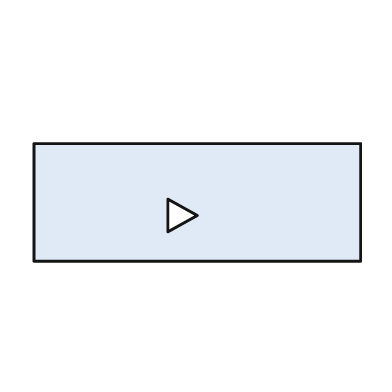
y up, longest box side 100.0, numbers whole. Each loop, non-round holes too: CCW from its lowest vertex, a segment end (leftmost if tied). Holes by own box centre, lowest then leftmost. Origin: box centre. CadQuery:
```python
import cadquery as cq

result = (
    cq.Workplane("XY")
    .moveTo(-50.0, -18.0)
    .lineTo(50.0, -18.0)
    .lineTo(50.0, 18.0)
    .lineTo(-50.0, 18.0)
    .close()
    .moveTo(-9.0, -9.0)
    .lineTo(0.0, -4.0)
    .lineTo(-9.0, 1.0)
    .close()
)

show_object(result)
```